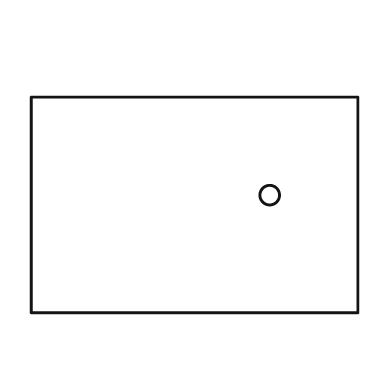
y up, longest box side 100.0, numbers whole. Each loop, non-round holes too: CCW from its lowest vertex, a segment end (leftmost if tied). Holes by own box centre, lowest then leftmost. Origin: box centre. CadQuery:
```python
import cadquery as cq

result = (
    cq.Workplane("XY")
    .moveTo(-50.0, -33.0)
    .lineTo(50.0, -33.0)
    .lineTo(50.0, 33.0)
    .lineTo(-50.0, 33.0)
    .close()
    .moveTo(23.0, 3.0)
    .circle(3.0)
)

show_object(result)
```